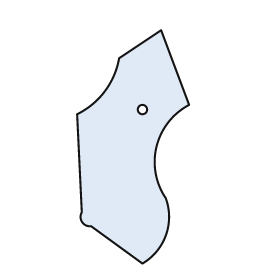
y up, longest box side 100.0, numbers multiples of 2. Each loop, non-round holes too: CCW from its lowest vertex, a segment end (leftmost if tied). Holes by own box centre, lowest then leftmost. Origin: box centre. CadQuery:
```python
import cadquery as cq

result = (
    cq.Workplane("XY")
    .moveTo(4.0, -50.0)
    .threePointArc((14.0, -38.0), (14.0, -22.0))
    .threePointArc((10.0, 0.0), (24.0, 18.0))
    .lineTo(12.0, 50.0)
    .lineTo(-6.0, 38.0)
    .threePointArc((-12.0, 24.0), (-24.0, 14.0))
    .lineTo(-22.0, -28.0)
    .threePointArc((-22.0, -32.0), (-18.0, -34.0))
    .close()
    .moveTo(4.0, 16.0)
    .circle(2.0)
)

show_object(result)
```